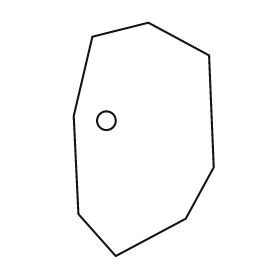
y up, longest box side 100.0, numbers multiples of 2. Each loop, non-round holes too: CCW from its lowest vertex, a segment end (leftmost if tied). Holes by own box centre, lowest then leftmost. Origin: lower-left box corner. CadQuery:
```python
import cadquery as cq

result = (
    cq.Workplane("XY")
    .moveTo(18.0, 0.0)
    .lineTo(48.0, 16.0)
    .lineTo(60.0, 38.0)
    .lineTo(58.0, 86.0)
    .lineTo(32.0, 100.0)
    .lineTo(8.0, 94.0)
    .lineTo(0.0, 60.0)
    .lineTo(2.0, 18.0)
    .close()
    .moveTo(14.0, 58.0)
    .circle(4.0)
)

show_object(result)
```